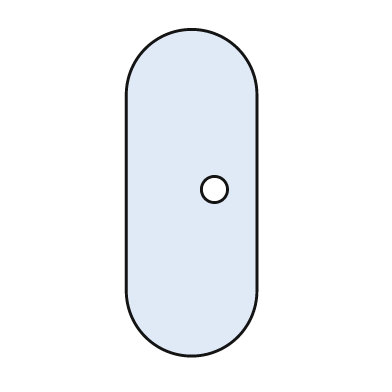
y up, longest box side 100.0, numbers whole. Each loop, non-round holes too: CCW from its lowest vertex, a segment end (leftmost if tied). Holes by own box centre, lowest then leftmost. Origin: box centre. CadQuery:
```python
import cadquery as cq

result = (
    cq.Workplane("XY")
    .moveTo(-20.0, -30.0)
    .threePointArc((0.0, -50.0), (20.0, -30.0))
    .lineTo(20.0, 30.0)
    .threePointArc((0.0, 50.0), (-20.0, 30.0))
    .close()
    .moveTo(7.0, 1.0)
    .circle(4.0)
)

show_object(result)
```